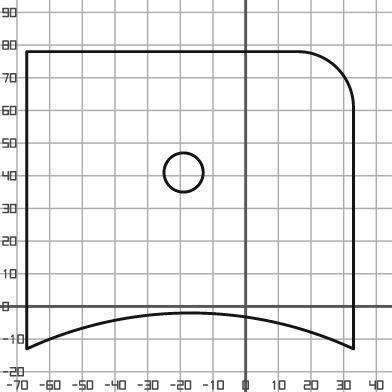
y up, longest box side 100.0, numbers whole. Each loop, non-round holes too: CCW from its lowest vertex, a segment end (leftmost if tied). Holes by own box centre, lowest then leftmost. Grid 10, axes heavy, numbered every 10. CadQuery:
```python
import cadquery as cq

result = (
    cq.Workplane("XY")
    .moveTo(-67.0, -13.0)
    .threePointArc((-17.0, -2.0), (33.0, -13.0))
    .lineTo(33.0, 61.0)
    .threePointArc((28.0, 73.0), (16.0, 78.0))
    .lineTo(-67.0, 78.0)
    .close()
    .moveTo(-19.0, 41.0)
    .circle(6.0)
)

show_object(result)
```